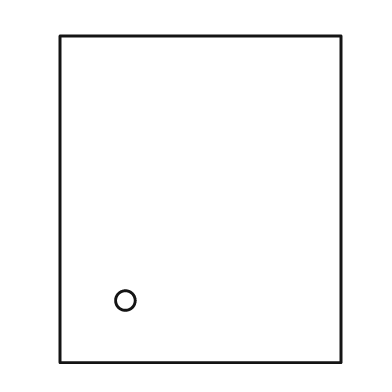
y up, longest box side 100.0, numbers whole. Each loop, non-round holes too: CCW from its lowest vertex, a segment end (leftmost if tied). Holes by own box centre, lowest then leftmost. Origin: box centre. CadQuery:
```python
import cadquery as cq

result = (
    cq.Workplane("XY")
    .moveTo(-43.0, -50.0)
    .lineTo(43.0, -50.0)
    .lineTo(43.0, 50.0)
    .lineTo(-43.0, 50.0)
    .close()
    .moveTo(-23.0, -31.0)
    .circle(3.0)
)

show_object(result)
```